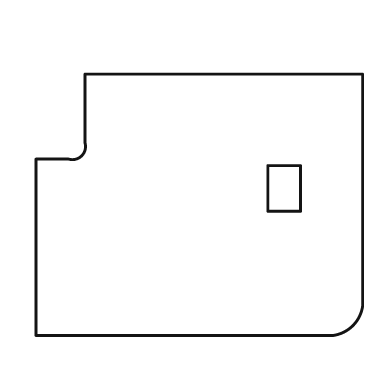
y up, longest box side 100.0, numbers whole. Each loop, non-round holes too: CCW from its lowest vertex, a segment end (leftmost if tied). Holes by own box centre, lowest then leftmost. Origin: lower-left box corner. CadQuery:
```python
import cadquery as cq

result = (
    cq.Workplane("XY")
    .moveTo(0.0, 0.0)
    .lineTo(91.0, 0.0)
    .threePointArc((97.0, 3.0), (100.0, 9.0))
    .lineTo(100.0, 80.0)
    .lineTo(15.0, 80.0)
    .lineTo(15.0, 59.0)
    .threePointArc((14.0, 55.0), (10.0, 54.0))
    .lineTo(0.0, 54.0)
    .close()
    .moveTo(71.0, 38.0)
    .lineTo(81.0, 38.0)
    .lineTo(81.0, 52.0)
    .lineTo(71.0, 52.0)
    .close()
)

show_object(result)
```